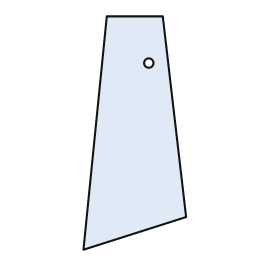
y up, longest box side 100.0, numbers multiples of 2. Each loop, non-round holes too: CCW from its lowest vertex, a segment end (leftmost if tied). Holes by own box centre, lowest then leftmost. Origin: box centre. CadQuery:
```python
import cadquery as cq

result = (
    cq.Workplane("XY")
    .moveTo(-22.0, -50.0)
    .lineTo(22.0, -36.0)
    .lineTo(12.0, 50.0)
    .lineTo(-12.0, 50.0)
    .close()
    .moveTo(6.0, 30.0)
    .circle(2.0)
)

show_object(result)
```